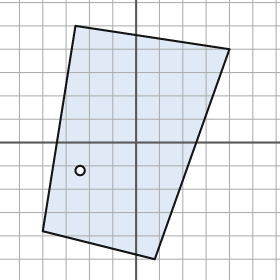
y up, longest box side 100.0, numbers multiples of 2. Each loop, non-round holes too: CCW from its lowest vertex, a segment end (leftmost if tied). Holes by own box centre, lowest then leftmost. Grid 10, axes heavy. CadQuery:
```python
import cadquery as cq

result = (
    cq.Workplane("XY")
    .moveTo(8.0, -50.0)
    .lineTo(40.0, 40.0)
    .lineTo(-26.0, 50.0)
    .lineTo(-40.0, -38.0)
    .close()
    .moveTo(-24.0, -12.0)
    .circle(2.0)
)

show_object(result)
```